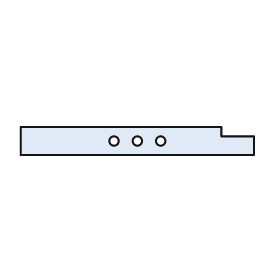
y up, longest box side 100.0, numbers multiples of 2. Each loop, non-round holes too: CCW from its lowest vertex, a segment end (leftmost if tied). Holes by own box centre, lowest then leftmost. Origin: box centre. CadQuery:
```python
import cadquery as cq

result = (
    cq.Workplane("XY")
    .moveTo(-50.0, -6.0)
    .lineTo(50.0, -6.0)
    .lineTo(50.0, 2.0)
    .lineTo(36.0, 2.0)
    .lineTo(36.0, 6.0)
    .lineTo(-50.0, 6.0)
    .close()
    .moveTo(-10.0, 0.0)
    .circle(2.0)
    .moveTo(0.0, 0.0)
    .circle(2.0)
    .moveTo(10.0, 0.0)
    .circle(2.0)
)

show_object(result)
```